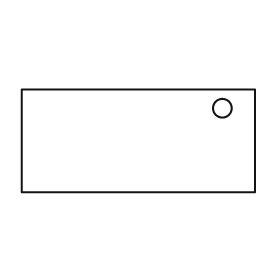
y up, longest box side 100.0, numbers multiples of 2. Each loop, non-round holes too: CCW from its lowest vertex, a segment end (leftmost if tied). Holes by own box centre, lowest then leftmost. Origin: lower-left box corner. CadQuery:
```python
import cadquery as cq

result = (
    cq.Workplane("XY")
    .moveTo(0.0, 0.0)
    .lineTo(100.0, 0.0)
    .lineTo(100.0, 44.0)
    .lineTo(0.0, 44.0)
    .close()
    .moveTo(86.0, 36.0)
    .circle(4.0)
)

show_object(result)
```